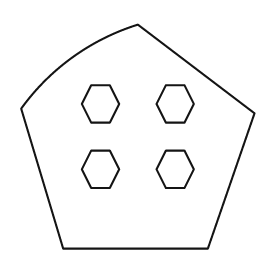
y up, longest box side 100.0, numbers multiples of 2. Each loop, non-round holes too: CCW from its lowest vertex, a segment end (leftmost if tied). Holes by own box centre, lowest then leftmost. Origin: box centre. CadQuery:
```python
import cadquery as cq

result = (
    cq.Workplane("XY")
    .moveTo(-32.0, -48.0)
    .lineTo(30.0, -48.0)
    .lineTo(50.0, 10.0)
    .lineTo(0.0, 48.0)
    .threePointArc((-28.0, 34.0), (-50.0, 12.0))
    .close()
    .moveTo(-20.0, -22.0)
    .lineTo(-12.0, -22.0)
    .lineTo(-8.0, -14.0)
    .lineTo(-12.0, -6.0)
    .lineTo(-20.0, -6.0)
    .lineTo(-24.0, -14.0)
    .close()
    .moveTo(12.0, -22.0)
    .lineTo(20.0, -22.0)
    .lineTo(24.0, -14.0)
    .lineTo(20.0, -6.0)
    .lineTo(12.0, -6.0)
    .lineTo(8.0, -14.0)
    .close()
    .moveTo(-20.0, 6.0)
    .lineTo(-12.0, 6.0)
    .lineTo(-8.0, 14.0)
    .lineTo(-12.0, 22.0)
    .lineTo(-20.0, 22.0)
    .lineTo(-24.0, 14.0)
    .close()
    .moveTo(12.0, 6.0)
    .lineTo(20.0, 6.0)
    .lineTo(24.0, 14.0)
    .lineTo(20.0, 22.0)
    .lineTo(12.0, 22.0)
    .lineTo(8.0, 14.0)
    .close()
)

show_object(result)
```